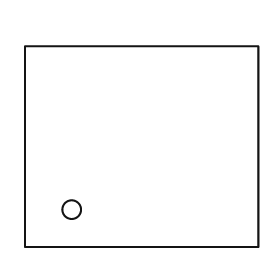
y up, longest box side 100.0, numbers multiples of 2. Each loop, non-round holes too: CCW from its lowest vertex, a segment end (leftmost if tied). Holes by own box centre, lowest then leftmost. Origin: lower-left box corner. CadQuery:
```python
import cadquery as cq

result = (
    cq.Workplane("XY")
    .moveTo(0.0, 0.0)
    .lineTo(100.0, 0.0)
    .lineTo(100.0, 86.0)
    .lineTo(0.0, 86.0)
    .close()
    .moveTo(20.0, 16.0)
    .circle(4.0)
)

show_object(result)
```